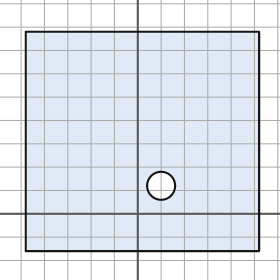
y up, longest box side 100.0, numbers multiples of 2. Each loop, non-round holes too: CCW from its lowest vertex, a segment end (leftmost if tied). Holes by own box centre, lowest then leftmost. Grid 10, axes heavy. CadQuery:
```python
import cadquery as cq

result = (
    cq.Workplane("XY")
    .moveTo(-48.0, -16.0)
    .lineTo(52.0, -16.0)
    .lineTo(52.0, 78.0)
    .lineTo(-48.0, 78.0)
    .close()
    .moveTo(10.0, 12.0)
    .circle(6.0)
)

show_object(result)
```